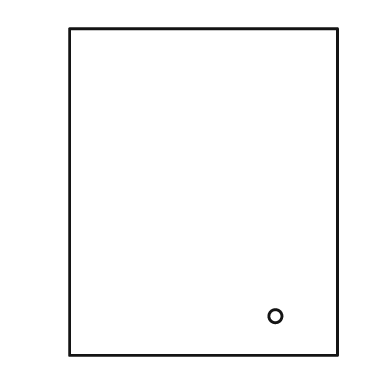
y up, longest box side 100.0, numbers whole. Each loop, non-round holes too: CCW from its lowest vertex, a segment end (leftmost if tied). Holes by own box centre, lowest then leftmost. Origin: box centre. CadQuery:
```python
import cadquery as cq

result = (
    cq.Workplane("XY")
    .moveTo(-41.0, -50.0)
    .lineTo(41.0, -50.0)
    .lineTo(41.0, 50.0)
    .lineTo(-41.0, 50.0)
    .close()
    .moveTo(22.0, -38.0)
    .circle(2.0)
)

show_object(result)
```